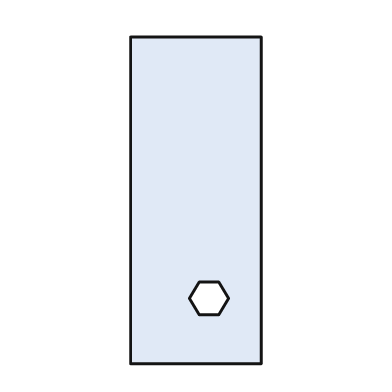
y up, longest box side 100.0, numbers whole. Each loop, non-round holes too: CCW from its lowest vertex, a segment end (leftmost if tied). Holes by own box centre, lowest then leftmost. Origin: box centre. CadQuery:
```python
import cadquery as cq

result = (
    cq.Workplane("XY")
    .moveTo(-20.0, -50.0)
    .lineTo(20.0, -50.0)
    .lineTo(20.0, 50.0)
    .lineTo(-20.0, 50.0)
    .close()
    .moveTo(1.0, -35.0)
    .lineTo(7.0, -35.0)
    .lineTo(10.0, -30.0)
    .lineTo(7.0, -25.0)
    .lineTo(1.0, -25.0)
    .lineTo(-2.0, -30.0)
    .close()
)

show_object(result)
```